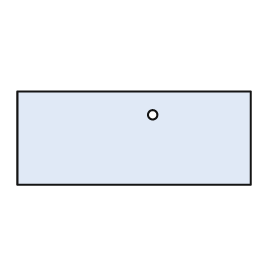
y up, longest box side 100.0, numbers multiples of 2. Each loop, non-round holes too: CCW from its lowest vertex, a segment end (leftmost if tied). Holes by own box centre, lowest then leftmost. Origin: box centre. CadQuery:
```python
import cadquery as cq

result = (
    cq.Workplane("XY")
    .moveTo(-50.0, -20.0)
    .lineTo(50.0, -20.0)
    .lineTo(50.0, 20.0)
    .lineTo(-50.0, 20.0)
    .close()
    .moveTo(8.0, 10.0)
    .circle(2.0)
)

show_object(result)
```